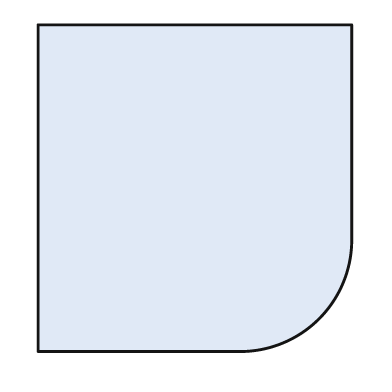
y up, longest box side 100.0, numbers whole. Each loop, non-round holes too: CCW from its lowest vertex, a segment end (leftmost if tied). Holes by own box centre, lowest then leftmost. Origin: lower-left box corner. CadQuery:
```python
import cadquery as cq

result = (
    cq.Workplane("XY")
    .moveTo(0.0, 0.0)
    .lineTo(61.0, 0.0)
    .threePointArc((86.0, 10.0), (96.0, 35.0))
    .lineTo(96.0, 100.0)
    .lineTo(0.0, 100.0)
    .close()
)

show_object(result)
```